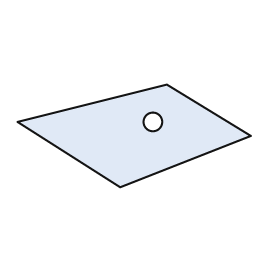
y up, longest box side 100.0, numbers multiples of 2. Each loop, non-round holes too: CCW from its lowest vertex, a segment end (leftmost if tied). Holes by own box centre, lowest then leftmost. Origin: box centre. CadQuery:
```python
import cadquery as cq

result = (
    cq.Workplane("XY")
    .moveTo(-6.0, -22.0)
    .lineTo(50.0, 0.0)
    .lineTo(14.0, 22.0)
    .lineTo(-50.0, 6.0)
    .close()
    .moveTo(8.0, 6.0)
    .circle(4.0)
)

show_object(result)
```